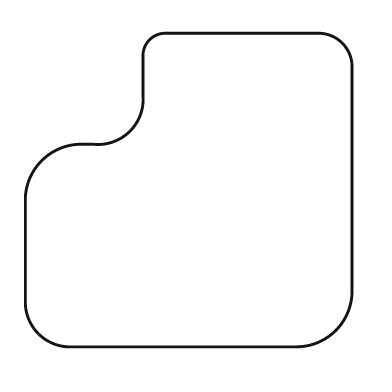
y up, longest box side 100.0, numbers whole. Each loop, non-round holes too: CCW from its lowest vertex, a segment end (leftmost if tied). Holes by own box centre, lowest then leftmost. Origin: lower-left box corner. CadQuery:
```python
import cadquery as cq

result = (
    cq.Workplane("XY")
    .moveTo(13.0, 0.0)
    .lineTo(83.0, 0.0)
    .threePointArc((95.0, 5.0), (100.0, 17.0))
    .lineTo(100.0, 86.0)
    .threePointArc((97.0, 93.0), (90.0, 96.0))
    .lineTo(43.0, 96.0)
    .threePointArc((38.0, 94.0), (36.0, 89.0))
    .lineTo(36.0, 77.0)
    .threePointArc((32.0, 66.0), (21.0, 62.0))
    .lineTo(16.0, 62.0)
    .threePointArc((5.0, 57.0), (0.0, 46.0))
    .lineTo(0.0, 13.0)
    .threePointArc((4.0, 4.0), (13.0, 0.0))
    .close()
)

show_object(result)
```